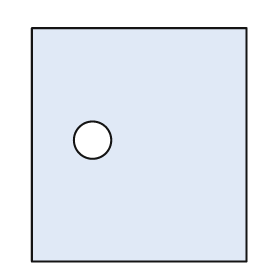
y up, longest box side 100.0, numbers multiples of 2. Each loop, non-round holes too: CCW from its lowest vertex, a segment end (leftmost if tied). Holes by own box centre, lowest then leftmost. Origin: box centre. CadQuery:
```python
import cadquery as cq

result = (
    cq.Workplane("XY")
    .moveTo(-46.0, -50.0)
    .lineTo(46.0, -50.0)
    .lineTo(46.0, 50.0)
    .lineTo(-46.0, 50.0)
    .close()
    .moveTo(-20.0, 2.0)
    .circle(8.0)
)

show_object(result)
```